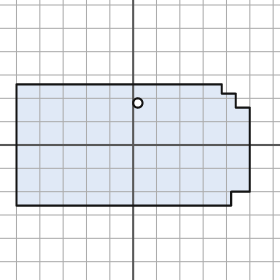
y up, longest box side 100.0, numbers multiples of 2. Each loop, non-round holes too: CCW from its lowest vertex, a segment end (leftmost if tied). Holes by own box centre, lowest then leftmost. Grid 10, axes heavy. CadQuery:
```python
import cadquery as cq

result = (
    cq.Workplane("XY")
    .moveTo(-50.0, -26.0)
    .lineTo(42.0, -26.0)
    .lineTo(42.0, -20.0)
    .lineTo(50.0, -20.0)
    .lineTo(50.0, 16.0)
    .lineTo(44.0, 16.0)
    .lineTo(44.0, 22.0)
    .lineTo(38.0, 22.0)
    .lineTo(38.0, 26.0)
    .lineTo(-50.0, 26.0)
    .close()
    .moveTo(2.0, 18.0)
    .circle(2.0)
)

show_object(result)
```